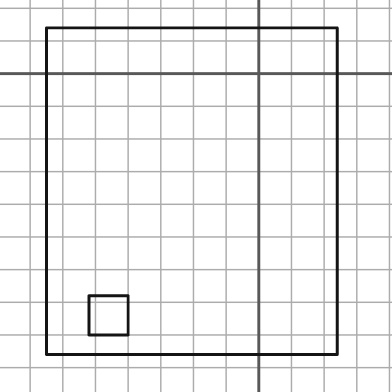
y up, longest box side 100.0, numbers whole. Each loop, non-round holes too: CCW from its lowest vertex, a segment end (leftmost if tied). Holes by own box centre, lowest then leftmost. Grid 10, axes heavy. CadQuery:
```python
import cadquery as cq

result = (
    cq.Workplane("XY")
    .moveTo(-65.0, -86.0)
    .lineTo(24.0, -86.0)
    .lineTo(24.0, 14.0)
    .lineTo(-65.0, 14.0)
    .close()
    .moveTo(-52.0, -80.0)
    .lineTo(-40.0, -80.0)
    .lineTo(-40.0, -68.0)
    .lineTo(-52.0, -68.0)
    .close()
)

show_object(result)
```